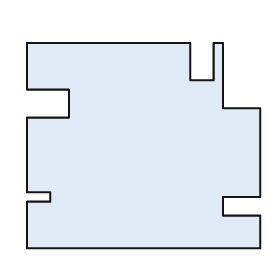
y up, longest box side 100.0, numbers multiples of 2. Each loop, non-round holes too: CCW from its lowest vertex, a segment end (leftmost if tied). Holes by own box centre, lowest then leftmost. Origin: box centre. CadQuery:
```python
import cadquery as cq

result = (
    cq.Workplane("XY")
    .moveTo(-50.0, -44.0)
    .lineTo(50.0, -44.0)
    .lineTo(50.0, -30.0)
    .lineTo(34.0, -30.0)
    .lineTo(34.0, -22.0)
    .lineTo(50.0, -22.0)
    .lineTo(50.0, 16.0)
    .lineTo(34.0, 16.0)
    .lineTo(34.0, 44.0)
    .lineTo(30.0, 44.0)
    .lineTo(30.0, 28.0)
    .lineTo(20.0, 28.0)
    .lineTo(20.0, 44.0)
    .lineTo(-50.0, 44.0)
    .lineTo(-50.0, 24.0)
    .lineTo(-32.0, 24.0)
    .lineTo(-32.0, 12.0)
    .lineTo(-50.0, 12.0)
    .lineTo(-50.0, -20.0)
    .lineTo(-40.0, -20.0)
    .lineTo(-40.0, -24.0)
    .lineTo(-50.0, -24.0)
    .close()
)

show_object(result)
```